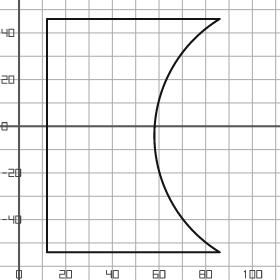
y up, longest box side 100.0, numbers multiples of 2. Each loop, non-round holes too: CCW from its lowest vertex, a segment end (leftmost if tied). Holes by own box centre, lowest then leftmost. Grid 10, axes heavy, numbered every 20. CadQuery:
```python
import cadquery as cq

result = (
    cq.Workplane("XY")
    .moveTo(12.0, -54.0)
    .lineTo(86.0, -54.0)
    .threePointArc((58.0, -4.0), (86.0, 46.0))
    .lineTo(12.0, 46.0)
    .close()
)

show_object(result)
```